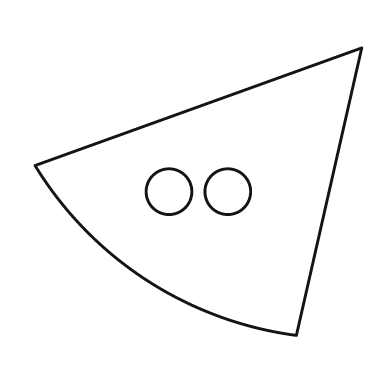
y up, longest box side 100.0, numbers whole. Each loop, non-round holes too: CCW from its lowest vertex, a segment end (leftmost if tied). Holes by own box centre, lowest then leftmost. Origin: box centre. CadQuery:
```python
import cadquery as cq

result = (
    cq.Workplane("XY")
    .moveTo(30.0, -44.0)
    .lineTo(50.0, 44.0)
    .lineTo(-50.0, 8.0)
    .threePointArc((-16.0, -27.0), (30.0, -44.0))
    .close()
    .moveTo(-9.0, 0.0)
    .circle(7.0)
    .moveTo(9.0, 0.0)
    .circle(7.0)
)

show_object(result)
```